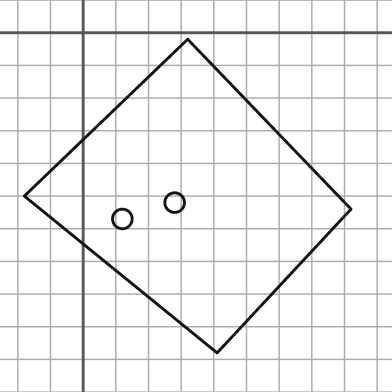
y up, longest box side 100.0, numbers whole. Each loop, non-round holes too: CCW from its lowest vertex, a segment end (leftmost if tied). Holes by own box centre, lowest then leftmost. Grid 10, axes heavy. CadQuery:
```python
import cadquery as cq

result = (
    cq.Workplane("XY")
    .moveTo(41.0, -98.0)
    .lineTo(82.0, -54.0)
    .lineTo(32.0, -2.0)
    .lineTo(-18.0, -50.0)
    .close()
    .moveTo(12.0, -57.0)
    .circle(3.0)
    .moveTo(28.0, -52.0)
    .circle(3.0)
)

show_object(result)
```